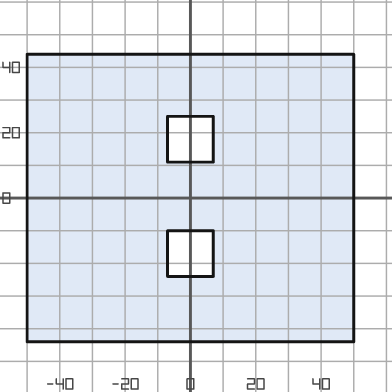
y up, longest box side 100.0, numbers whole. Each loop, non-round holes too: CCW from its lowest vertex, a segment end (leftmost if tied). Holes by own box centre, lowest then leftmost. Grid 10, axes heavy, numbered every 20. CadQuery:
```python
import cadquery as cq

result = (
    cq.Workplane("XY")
    .moveTo(-50.0, -44.0)
    .lineTo(50.0, -44.0)
    .lineTo(50.0, 44.0)
    .lineTo(-50.0, 44.0)
    .close()
    .moveTo(-7.0, -24.0)
    .lineTo(7.0, -24.0)
    .lineTo(7.0, -10.0)
    .lineTo(-7.0, -10.0)
    .close()
    .moveTo(-7.0, 11.0)
    .lineTo(7.0, 11.0)
    .lineTo(7.0, 25.0)
    .lineTo(-7.0, 25.0)
    .close()
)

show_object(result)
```